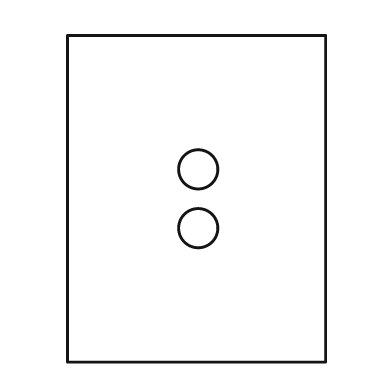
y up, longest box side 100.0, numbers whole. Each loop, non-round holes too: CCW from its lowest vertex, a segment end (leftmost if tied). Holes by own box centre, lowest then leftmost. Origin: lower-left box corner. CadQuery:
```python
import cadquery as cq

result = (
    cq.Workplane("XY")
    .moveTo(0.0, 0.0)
    .lineTo(79.0, 0.0)
    .lineTo(79.0, 100.0)
    .lineTo(0.0, 100.0)
    .close()
    .moveTo(40.0, 41.0)
    .circle(6.0)
    .moveTo(40.0, 59.0)
    .circle(6.0)
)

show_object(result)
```